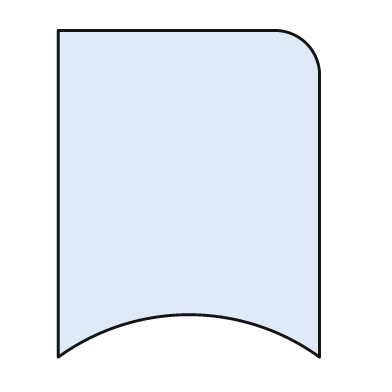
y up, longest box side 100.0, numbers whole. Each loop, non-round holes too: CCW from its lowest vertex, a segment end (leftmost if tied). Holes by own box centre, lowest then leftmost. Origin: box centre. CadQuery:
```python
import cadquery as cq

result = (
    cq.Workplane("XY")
    .moveTo(-40.0, -50.0)
    .threePointArc((0.0, -37.0), (40.0, -50.0))
    .lineTo(40.0, 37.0)
    .threePointArc((36.0, 46.0), (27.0, 50.0))
    .lineTo(-40.0, 50.0)
    .close()
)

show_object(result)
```